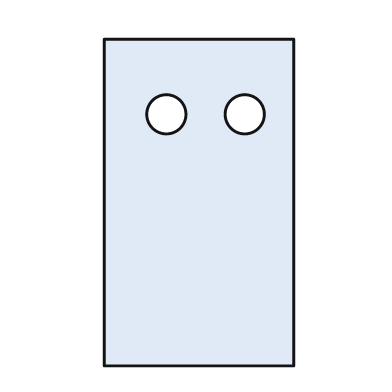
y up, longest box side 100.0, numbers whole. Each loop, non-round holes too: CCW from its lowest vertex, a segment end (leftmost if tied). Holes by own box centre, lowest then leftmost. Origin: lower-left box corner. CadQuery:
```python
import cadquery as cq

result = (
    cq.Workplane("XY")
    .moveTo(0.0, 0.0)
    .lineTo(58.0, 0.0)
    .lineTo(58.0, 100.0)
    .lineTo(0.0, 100.0)
    .close()
    .moveTo(19.0, 77.0)
    .circle(6.0)
    .moveTo(43.0, 77.0)
    .circle(6.0)
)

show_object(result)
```